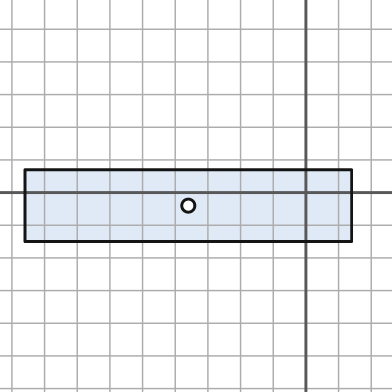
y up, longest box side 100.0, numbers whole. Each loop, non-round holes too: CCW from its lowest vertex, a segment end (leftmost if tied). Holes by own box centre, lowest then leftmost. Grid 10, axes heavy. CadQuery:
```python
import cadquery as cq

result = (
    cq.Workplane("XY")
    .moveTo(-86.0, -15.0)
    .lineTo(14.0, -15.0)
    .lineTo(14.0, 7.0)
    .lineTo(-86.0, 7.0)
    .close()
    .moveTo(-36.0, -4.0)
    .circle(2.0)
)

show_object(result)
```